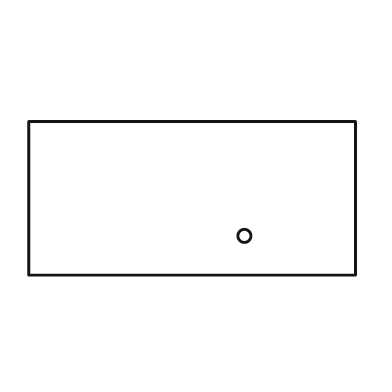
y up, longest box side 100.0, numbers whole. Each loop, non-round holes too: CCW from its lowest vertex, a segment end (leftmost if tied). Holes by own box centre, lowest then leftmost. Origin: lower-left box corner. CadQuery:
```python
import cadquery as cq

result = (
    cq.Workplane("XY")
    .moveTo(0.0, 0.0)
    .lineTo(100.0, 0.0)
    .lineTo(100.0, 47.0)
    .lineTo(0.0, 47.0)
    .close()
    .moveTo(66.0, 12.0)
    .circle(2.0)
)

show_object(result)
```